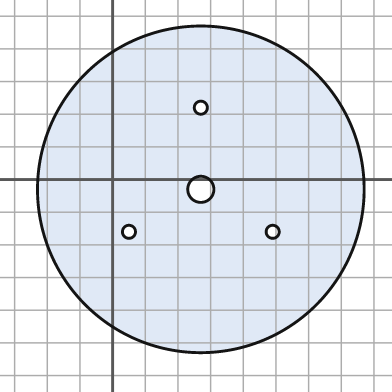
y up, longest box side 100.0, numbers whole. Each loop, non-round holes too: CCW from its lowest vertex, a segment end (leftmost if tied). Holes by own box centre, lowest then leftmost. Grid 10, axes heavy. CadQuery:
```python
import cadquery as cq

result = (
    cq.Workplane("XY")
    .moveTo(27.0, -3.0)
    .circle(50.0)
    .moveTo(5.0, -16.0)
    .circle(2.0)
    .moveTo(49.0, -16.0)
    .circle(2.0)
    .moveTo(27.0, -3.0)
    .circle(4.0)
    .moveTo(27.0, 22.0)
    .circle(2.0)
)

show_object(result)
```